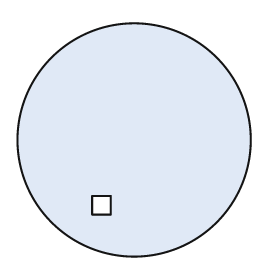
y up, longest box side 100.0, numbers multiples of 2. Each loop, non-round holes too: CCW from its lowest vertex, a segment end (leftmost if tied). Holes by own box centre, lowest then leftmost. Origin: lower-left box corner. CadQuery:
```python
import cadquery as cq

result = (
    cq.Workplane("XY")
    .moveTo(50.0, 50.0)
    .circle(50.0)
    .moveTo(32.0, 18.0)
    .lineTo(40.0, 18.0)
    .lineTo(40.0, 26.0)
    .lineTo(32.0, 26.0)
    .close()
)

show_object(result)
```